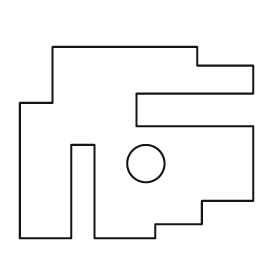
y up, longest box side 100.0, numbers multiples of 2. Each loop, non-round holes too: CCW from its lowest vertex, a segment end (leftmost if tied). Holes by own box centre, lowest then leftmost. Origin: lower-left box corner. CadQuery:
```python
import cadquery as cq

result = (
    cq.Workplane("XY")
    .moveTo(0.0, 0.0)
    .lineTo(22.0, 0.0)
    .lineTo(22.0, 40.0)
    .lineTo(32.0, 40.0)
    .lineTo(32.0, 0.0)
    .lineTo(58.0, 0.0)
    .lineTo(58.0, 6.0)
    .lineTo(78.0, 6.0)
    .lineTo(78.0, 16.0)
    .lineTo(100.0, 16.0)
    .lineTo(100.0, 48.0)
    .lineTo(50.0, 48.0)
    .lineTo(50.0, 62.0)
    .lineTo(100.0, 62.0)
    .lineTo(100.0, 74.0)
    .lineTo(76.0, 74.0)
    .lineTo(76.0, 82.0)
    .lineTo(14.0, 82.0)
    .lineTo(14.0, 58.0)
    .lineTo(0.0, 58.0)
    .close()
    .moveTo(54.0, 32.0)
    .circle(8.0)
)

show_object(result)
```